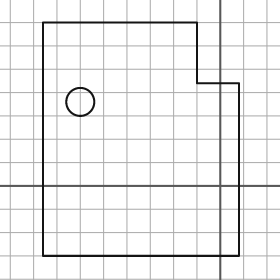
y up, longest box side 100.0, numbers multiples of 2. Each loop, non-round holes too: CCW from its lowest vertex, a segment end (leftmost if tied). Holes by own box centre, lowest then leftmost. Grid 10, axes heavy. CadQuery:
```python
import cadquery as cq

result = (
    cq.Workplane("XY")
    .moveTo(-76.0, -30.0)
    .lineTo(8.0, -30.0)
    .lineTo(8.0, 44.0)
    .lineTo(-10.0, 44.0)
    .lineTo(-10.0, 70.0)
    .lineTo(-76.0, 70.0)
    .close()
    .moveTo(-60.0, 36.0)
    .circle(6.0)
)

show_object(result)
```